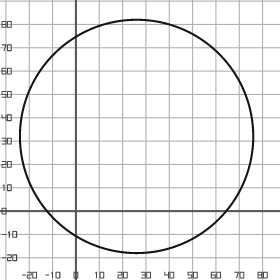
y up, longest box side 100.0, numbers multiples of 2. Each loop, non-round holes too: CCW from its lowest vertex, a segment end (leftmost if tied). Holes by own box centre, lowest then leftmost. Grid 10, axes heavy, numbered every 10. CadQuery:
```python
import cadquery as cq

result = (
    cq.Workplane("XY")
    .moveTo(26.0, 32.0)
    .circle(50.0)
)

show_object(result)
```